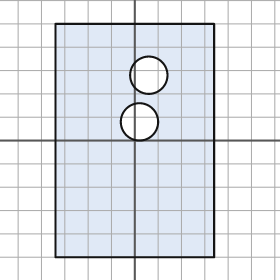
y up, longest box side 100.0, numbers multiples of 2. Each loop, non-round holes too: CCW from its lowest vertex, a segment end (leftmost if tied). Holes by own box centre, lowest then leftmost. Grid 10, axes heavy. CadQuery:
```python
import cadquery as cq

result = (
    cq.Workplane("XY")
    .moveTo(-34.0, -50.0)
    .lineTo(34.0, -50.0)
    .lineTo(34.0, 50.0)
    .lineTo(-34.0, 50.0)
    .close()
    .moveTo(2.0, 8.0)
    .circle(8.0)
    .moveTo(6.0, 28.0)
    .circle(8.0)
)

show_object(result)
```